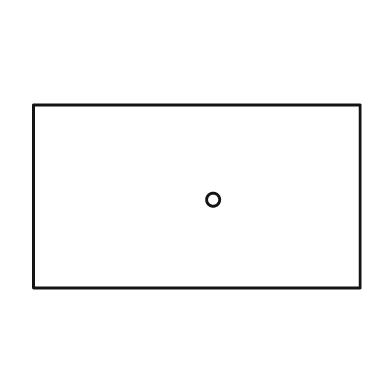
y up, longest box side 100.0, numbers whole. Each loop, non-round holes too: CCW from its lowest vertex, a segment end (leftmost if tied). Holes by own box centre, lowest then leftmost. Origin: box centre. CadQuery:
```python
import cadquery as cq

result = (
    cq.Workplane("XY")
    .moveTo(-50.0, -28.0)
    .lineTo(50.0, -28.0)
    .lineTo(50.0, 28.0)
    .lineTo(-50.0, 28.0)
    .close()
    .moveTo(5.0, -1.0)
    .circle(2.0)
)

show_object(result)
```